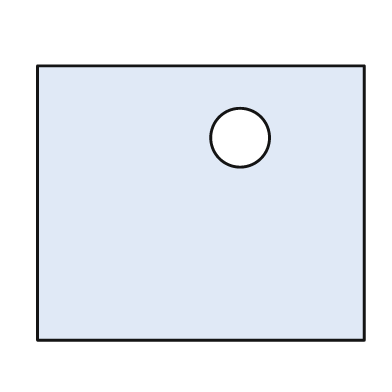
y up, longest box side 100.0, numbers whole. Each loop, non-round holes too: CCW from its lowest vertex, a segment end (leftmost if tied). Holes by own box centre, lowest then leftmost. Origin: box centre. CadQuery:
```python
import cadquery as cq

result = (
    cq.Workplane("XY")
    .moveTo(-50.0, -42.0)
    .lineTo(50.0, -42.0)
    .lineTo(50.0, 42.0)
    .lineTo(-50.0, 42.0)
    .close()
    .moveTo(12.0, 20.0)
    .circle(9.0)
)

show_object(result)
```